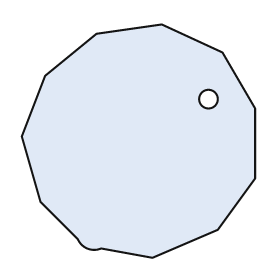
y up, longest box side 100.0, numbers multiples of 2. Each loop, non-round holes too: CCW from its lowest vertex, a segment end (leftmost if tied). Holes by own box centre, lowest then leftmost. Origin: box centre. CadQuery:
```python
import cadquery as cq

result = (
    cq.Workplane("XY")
    .moveTo(6.0, -50.0)
    .lineTo(34.0, -38.0)
    .lineTo(50.0, -16.0)
    .lineTo(50.0, 14.0)
    .lineTo(36.0, 38.0)
    .lineTo(10.0, 50.0)
    .lineTo(-18.0, 46.0)
    .lineTo(-40.0, 28.0)
    .lineTo(-50.0, 2.0)
    .lineTo(-42.0, -26.0)
    .lineTo(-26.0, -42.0)
    .threePointArc((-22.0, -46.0), (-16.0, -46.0))
    .close()
    .moveTo(30.0, 18.0)
    .circle(4.0)
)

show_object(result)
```